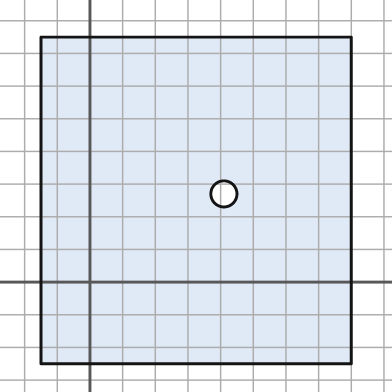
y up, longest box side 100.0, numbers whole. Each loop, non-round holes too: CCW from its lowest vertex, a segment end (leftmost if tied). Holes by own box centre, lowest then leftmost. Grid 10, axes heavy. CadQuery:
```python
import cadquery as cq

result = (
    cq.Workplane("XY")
    .moveTo(-15.0, -25.0)
    .lineTo(80.0, -25.0)
    .lineTo(80.0, 75.0)
    .lineTo(-15.0, 75.0)
    .close()
    .moveTo(41.0, 27.0)
    .circle(4.0)
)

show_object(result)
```